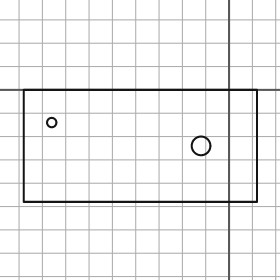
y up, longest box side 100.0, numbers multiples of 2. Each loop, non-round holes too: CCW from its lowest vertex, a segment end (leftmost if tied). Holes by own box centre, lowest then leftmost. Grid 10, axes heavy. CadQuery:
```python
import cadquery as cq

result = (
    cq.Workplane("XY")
    .moveTo(-88.0, -48.0)
    .lineTo(12.0, -48.0)
    .lineTo(12.0, 0.0)
    .lineTo(-88.0, 0.0)
    .close()
    .moveTo(-12.0, -24.0)
    .circle(4.0)
    .moveTo(-76.0, -14.0)
    .circle(2.0)
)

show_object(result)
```